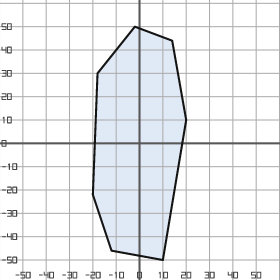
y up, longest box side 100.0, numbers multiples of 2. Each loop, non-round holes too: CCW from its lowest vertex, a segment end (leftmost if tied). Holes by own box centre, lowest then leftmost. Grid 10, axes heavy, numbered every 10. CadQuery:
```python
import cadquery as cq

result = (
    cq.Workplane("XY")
    .moveTo(10.0, -50.0)
    .lineTo(20.0, 10.0)
    .lineTo(14.0, 44.0)
    .lineTo(-2.0, 50.0)
    .lineTo(-18.0, 30.0)
    .lineTo(-20.0, -22.0)
    .lineTo(-12.0, -46.0)
    .close()
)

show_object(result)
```